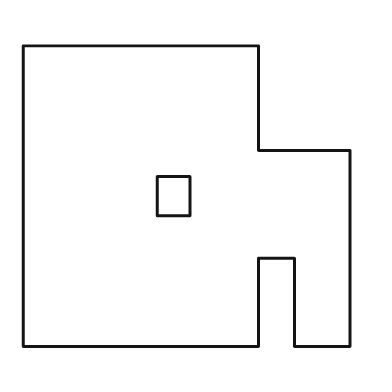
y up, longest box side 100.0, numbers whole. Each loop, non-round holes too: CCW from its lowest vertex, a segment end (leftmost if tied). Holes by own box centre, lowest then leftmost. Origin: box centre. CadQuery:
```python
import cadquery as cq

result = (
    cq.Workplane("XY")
    .moveTo(-50.0, -46.0)
    .lineTo(22.0, -46.0)
    .lineTo(22.0, -19.0)
    .lineTo(33.0, -19.0)
    .lineTo(33.0, -46.0)
    .lineTo(50.0, -46.0)
    .lineTo(50.0, 14.0)
    .lineTo(22.0, 14.0)
    .lineTo(22.0, 46.0)
    .lineTo(-50.0, 46.0)
    .close()
    .moveTo(-9.0, -6.0)
    .lineTo(1.0, -6.0)
    .lineTo(1.0, 6.0)
    .lineTo(-9.0, 6.0)
    .close()
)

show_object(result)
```